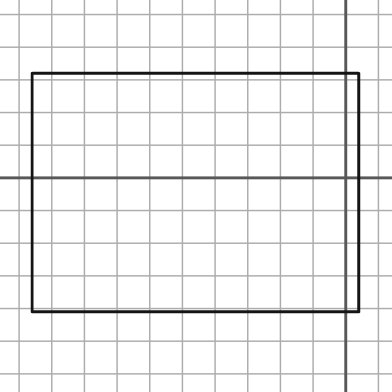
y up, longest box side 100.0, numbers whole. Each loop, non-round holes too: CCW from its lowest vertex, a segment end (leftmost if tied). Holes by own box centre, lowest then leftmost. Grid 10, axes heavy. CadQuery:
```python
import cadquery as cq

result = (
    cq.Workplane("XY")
    .moveTo(-96.0, -41.0)
    .lineTo(4.0, -41.0)
    .lineTo(4.0, 32.0)
    .lineTo(-96.0, 32.0)
    .close()
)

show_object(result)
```